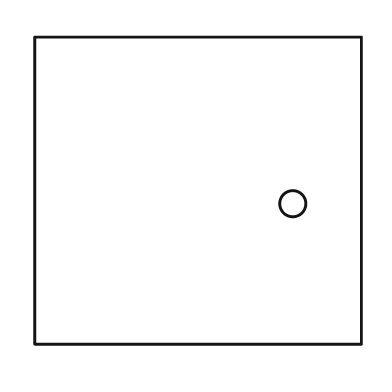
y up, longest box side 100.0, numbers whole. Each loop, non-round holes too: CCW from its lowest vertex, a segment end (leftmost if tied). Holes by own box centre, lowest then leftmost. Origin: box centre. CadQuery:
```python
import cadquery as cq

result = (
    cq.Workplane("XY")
    .moveTo(-50.0, -47.0)
    .lineTo(50.0, -47.0)
    .lineTo(50.0, 47.0)
    .lineTo(-50.0, 47.0)
    .close()
    .moveTo(29.0, -4.0)
    .circle(4.0)
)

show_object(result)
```